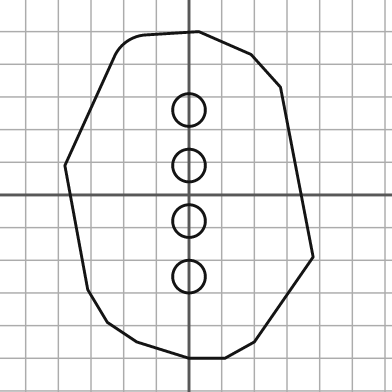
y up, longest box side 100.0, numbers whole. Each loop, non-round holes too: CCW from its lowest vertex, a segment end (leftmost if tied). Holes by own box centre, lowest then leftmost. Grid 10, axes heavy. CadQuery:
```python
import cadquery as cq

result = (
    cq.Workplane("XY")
    .moveTo(0.0, -50.0)
    .lineTo(11.0, -50.0)
    .lineTo(20.0, -45.0)
    .lineTo(38.0, -19.0)
    .lineTo(28.0, 33.0)
    .lineTo(19.0, 43.0)
    .lineTo(3.0, 50.0)
    .lineTo(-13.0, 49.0)
    .threePointArc((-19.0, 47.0), (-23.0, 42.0))
    .lineTo(-38.0, 9.0)
    .lineTo(-31.0, -29.0)
    .lineTo(-25.0, -39.0)
    .lineTo(-16.0, -45.0)
    .close()
    .moveTo(0.0, -25.0)
    .circle(5.0)
    .moveTo(0.0, -8.0)
    .circle(5.0)
    .moveTo(0.0, 9.0)
    .circle(5.0)
    .moveTo(0.0, 26.0)
    .circle(5.0)
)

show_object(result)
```